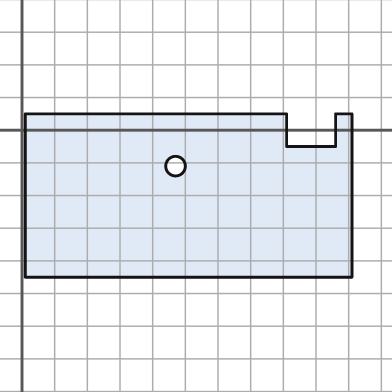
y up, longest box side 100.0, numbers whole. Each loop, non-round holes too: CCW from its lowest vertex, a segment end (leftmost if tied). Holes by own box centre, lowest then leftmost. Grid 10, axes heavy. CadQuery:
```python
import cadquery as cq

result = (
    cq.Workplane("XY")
    .moveTo(1.0, -45.0)
    .lineTo(101.0, -45.0)
    .lineTo(101.0, 5.0)
    .lineTo(96.0, 5.0)
    .lineTo(96.0, -5.0)
    .lineTo(81.0, -5.0)
    .lineTo(81.0, 5.0)
    .lineTo(1.0, 5.0)
    .close()
    .moveTo(47.0, -11.0)
    .circle(3.0)
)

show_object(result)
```